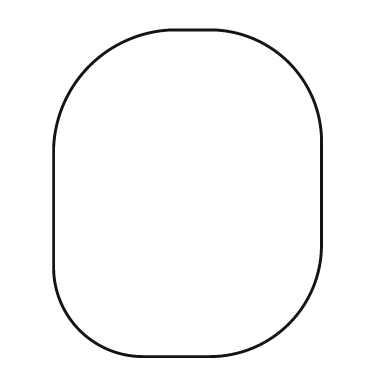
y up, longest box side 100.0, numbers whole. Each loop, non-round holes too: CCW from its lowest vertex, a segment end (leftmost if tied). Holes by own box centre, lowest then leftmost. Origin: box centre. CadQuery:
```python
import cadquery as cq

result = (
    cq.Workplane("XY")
    .moveTo(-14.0, -50.0)
    .lineTo(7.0, -50.0)
    .threePointArc((31.0, -40.0), (41.0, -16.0))
    .lineTo(41.0, 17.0)
    .threePointArc((31.0, 40.0), (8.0, 50.0))
    .lineTo(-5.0, 50.0)
    .threePointArc((-30.0, 39.0), (-41.0, 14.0))
    .lineTo(-41.0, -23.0)
    .threePointArc((-33.0, -42.0), (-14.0, -50.0))
    .close()
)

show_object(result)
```